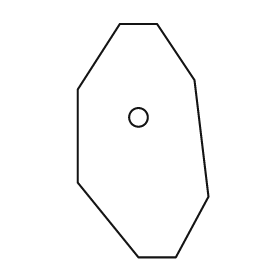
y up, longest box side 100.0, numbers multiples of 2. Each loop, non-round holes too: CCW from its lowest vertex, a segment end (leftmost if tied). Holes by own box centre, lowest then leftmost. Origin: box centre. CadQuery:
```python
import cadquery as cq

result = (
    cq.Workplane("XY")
    .moveTo(-2.0, -50.0)
    .lineTo(14.0, -50.0)
    .lineTo(28.0, -24.0)
    .lineTo(22.0, 26.0)
    .lineTo(6.0, 50.0)
    .lineTo(-10.0, 50.0)
    .lineTo(-28.0, 22.0)
    .lineTo(-28.0, -18.0)
    .close()
    .moveTo(-2.0, 10.0)
    .circle(4.0)
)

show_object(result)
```